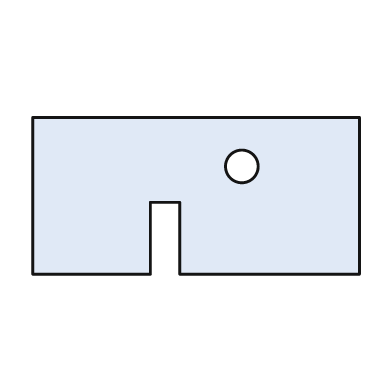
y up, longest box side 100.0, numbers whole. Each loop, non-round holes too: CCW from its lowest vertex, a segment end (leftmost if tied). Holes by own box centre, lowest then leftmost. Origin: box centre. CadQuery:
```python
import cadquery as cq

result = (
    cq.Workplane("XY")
    .moveTo(-50.0, -24.0)
    .lineTo(-14.0, -24.0)
    .lineTo(-14.0, -2.0)
    .lineTo(-5.0, -2.0)
    .lineTo(-5.0, -24.0)
    .lineTo(50.0, -24.0)
    .lineTo(50.0, 24.0)
    .lineTo(-50.0, 24.0)
    .close()
    .moveTo(14.0, 9.0)
    .circle(5.0)
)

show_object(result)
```